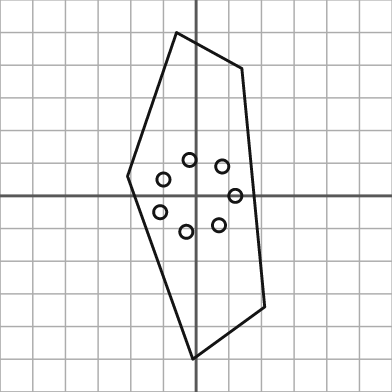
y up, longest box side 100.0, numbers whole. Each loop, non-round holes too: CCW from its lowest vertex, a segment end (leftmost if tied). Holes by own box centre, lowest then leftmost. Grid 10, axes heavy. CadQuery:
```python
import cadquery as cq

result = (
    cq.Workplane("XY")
    .moveTo(-1.0, -50.0)
    .lineTo(21.0, -34.0)
    .lineTo(14.0, 39.0)
    .lineTo(-6.0, 50.0)
    .lineTo(-21.0, 6.0)
    .close()
    .moveTo(-3.0, -11.0)
    .circle(2.0)
    .moveTo(7.0, -9.0)
    .circle(2.0)
    .moveTo(-11.0, -5.0)
    .circle(2.0)
    .moveTo(12.0, 0.0)
    .circle(2.0)
    .moveTo(-10.0, 5.0)
    .circle(2.0)
    .moveTo(8.0, 9.0)
    .circle(2.0)
    .moveTo(-2.0, 11.0)
    .circle(2.0)
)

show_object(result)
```